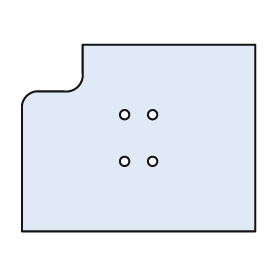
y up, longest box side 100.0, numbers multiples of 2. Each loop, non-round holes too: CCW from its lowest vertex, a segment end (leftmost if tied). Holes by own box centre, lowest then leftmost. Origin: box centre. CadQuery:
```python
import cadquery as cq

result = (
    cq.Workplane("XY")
    .moveTo(-50.0, -40.0)
    .lineTo(50.0, -40.0)
    .lineTo(50.0, 40.0)
    .lineTo(-24.0, 40.0)
    .lineTo(-24.0, 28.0)
    .threePointArc((-26.0, 22.0), (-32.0, 20.0))
    .lineTo(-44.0, 20.0)
    .threePointArc((-48.0, 18.0), (-50.0, 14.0))
    .close()
    .moveTo(-6.0, -10.0)
    .circle(2.0)
    .moveTo(6.0, -10.0)
    .circle(2.0)
    .moveTo(-6.0, 10.0)
    .circle(2.0)
    .moveTo(6.0, 10.0)
    .circle(2.0)
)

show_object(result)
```